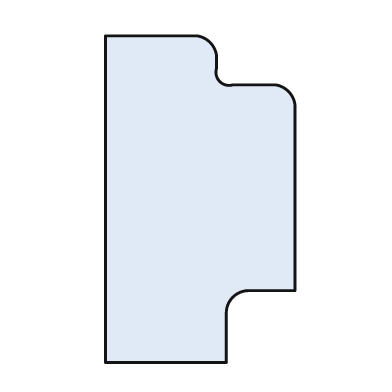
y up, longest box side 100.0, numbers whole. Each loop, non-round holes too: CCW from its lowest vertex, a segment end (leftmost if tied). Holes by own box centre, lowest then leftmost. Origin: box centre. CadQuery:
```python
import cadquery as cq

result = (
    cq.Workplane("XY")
    .moveTo(-29.0, -50.0)
    .lineTo(8.0, -50.0)
    .lineTo(8.0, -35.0)
    .threePointArc((10.0, -30.0), (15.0, -28.0))
    .lineTo(29.0, -28.0)
    .lineTo(29.0, 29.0)
    .threePointArc((27.0, 33.0), (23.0, 35.0))
    .lineTo(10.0, 35.0)
    .threePointArc((6.0, 36.0), (5.0, 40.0))
    .lineTo(5.0, 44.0)
    .threePointArc((3.0, 48.0), (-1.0, 50.0))
    .lineTo(-29.0, 50.0)
    .close()
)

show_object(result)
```